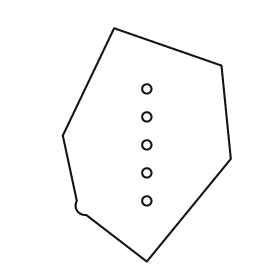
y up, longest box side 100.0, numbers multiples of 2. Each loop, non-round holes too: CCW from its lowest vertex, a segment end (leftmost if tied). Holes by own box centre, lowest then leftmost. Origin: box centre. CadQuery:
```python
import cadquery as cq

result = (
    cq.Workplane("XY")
    .moveTo(0.0, -50.0)
    .lineTo(36.0, -6.0)
    .lineTo(32.0, 34.0)
    .lineTo(-14.0, 50.0)
    .lineTo(-36.0, 4.0)
    .lineTo(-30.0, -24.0)
    .threePointArc((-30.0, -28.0), (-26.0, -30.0))
    .close()
    .moveTo(0.0, -24.0)
    .circle(2.0)
    .moveTo(0.0, -12.0)
    .circle(2.0)
    .moveTo(0.0, 0.0)
    .circle(2.0)
    .moveTo(0.0, 12.0)
    .circle(2.0)
    .moveTo(0.0, 24.0)
    .circle(2.0)
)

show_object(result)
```